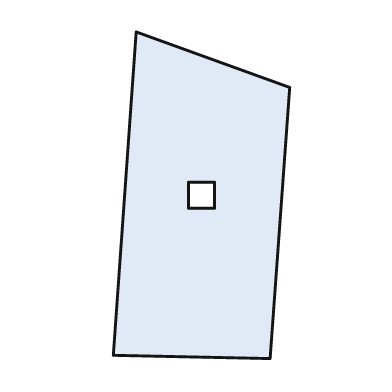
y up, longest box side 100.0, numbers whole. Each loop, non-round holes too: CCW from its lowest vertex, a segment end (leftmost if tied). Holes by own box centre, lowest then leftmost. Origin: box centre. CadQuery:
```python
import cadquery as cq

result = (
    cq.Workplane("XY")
    .moveTo(21.0, -50.0)
    .lineTo(27.0, 33.0)
    .lineTo(-20.0, 50.0)
    .lineTo(-27.0, -49.0)
    .close()
    .moveTo(-4.0, -4.0)
    .lineTo(4.0, -4.0)
    .lineTo(4.0, 4.0)
    .lineTo(-4.0, 4.0)
    .close()
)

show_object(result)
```